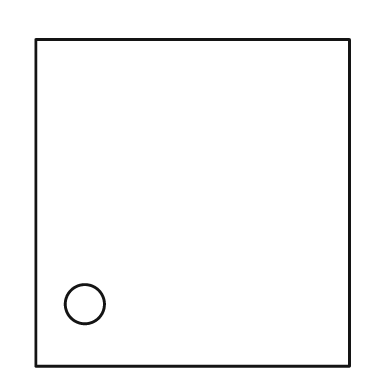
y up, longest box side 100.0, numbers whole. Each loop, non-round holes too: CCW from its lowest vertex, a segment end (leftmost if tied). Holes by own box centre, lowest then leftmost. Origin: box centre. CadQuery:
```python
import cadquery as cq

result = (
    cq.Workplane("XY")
    .moveTo(-48.0, -50.0)
    .lineTo(48.0, -50.0)
    .lineTo(48.0, 50.0)
    .lineTo(-48.0, 50.0)
    .close()
    .moveTo(-33.0, -31.0)
    .circle(6.0)
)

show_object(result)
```